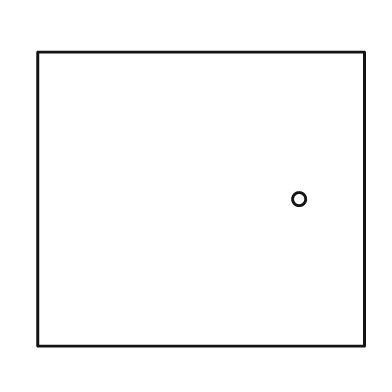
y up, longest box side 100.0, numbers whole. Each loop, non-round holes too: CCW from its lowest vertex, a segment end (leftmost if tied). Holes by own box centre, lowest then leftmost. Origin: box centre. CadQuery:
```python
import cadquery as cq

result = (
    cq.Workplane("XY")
    .moveTo(-50.0, -45.0)
    .lineTo(50.0, -45.0)
    .lineTo(50.0, 45.0)
    .lineTo(-50.0, 45.0)
    .close()
    .moveTo(30.0, 0.0)
    .circle(2.0)
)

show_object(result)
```